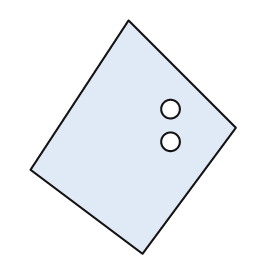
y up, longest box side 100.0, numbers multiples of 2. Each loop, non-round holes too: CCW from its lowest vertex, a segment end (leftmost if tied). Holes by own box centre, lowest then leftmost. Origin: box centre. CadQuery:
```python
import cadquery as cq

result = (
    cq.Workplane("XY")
    .moveTo(4.0, -50.0)
    .lineTo(44.0, 4.0)
    .lineTo(-2.0, 50.0)
    .lineTo(-44.0, -14.0)
    .close()
    .moveTo(16.0, -2.0)
    .circle(4.0)
    .moveTo(16.0, 12.0)
    .circle(4.0)
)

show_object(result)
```